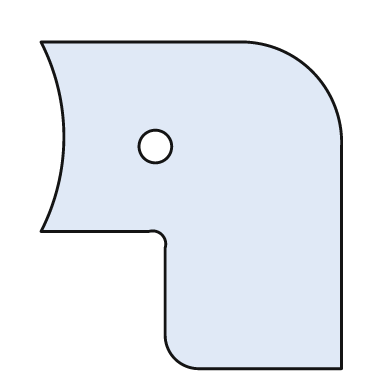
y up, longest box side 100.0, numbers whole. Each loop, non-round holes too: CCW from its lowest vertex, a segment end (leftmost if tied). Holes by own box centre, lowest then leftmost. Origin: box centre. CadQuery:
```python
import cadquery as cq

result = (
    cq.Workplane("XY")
    .moveTo(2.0, -50.0)
    .lineTo(46.0, -50.0)
    .lineTo(46.0, 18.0)
    .threePointArc((37.0, 41.0), (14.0, 50.0))
    .lineTo(-46.0, 50.0)
    .threePointArc((-39.0, 21.0), (-46.0, -8.0))
    .lineTo(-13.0, -8.0)
    .threePointArc((-9.0, -9.0), (-8.0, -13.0))
    .lineTo(-8.0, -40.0)
    .threePointArc((-5.0, -47.0), (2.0, -50.0))
    .close()
    .moveTo(-11.0, 18.0)
    .circle(5.0)
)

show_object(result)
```